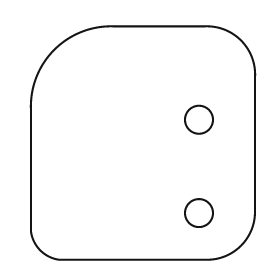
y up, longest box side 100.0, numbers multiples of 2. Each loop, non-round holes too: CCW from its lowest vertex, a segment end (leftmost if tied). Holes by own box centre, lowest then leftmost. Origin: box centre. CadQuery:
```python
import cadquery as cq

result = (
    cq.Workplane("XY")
    .moveTo(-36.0, -50.0)
    .lineTo(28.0, -50.0)
    .threePointArc((42.0, -44.0), (48.0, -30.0))
    .lineTo(48.0, 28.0)
    .threePointArc((42.0, 44.0), (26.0, 50.0))
    .lineTo(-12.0, 50.0)
    .threePointArc((-38.0, 40.0), (-48.0, 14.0))
    .lineTo(-48.0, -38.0)
    .threePointArc((-44.0, -46.0), (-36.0, -50.0))
    .close()
    .moveTo(24.0, -30.0)
    .circle(6.0)
    .moveTo(24.0, 10.0)
    .circle(6.0)
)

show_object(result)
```